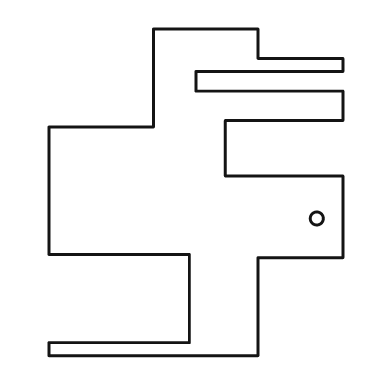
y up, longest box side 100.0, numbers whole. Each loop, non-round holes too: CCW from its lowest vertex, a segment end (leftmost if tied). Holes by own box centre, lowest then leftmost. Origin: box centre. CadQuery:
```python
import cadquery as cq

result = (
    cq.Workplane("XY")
    .moveTo(-45.0, -50.0)
    .lineTo(19.0, -50.0)
    .lineTo(19.0, -20.0)
    .lineTo(45.0, -20.0)
    .lineTo(45.0, 5.0)
    .lineTo(9.0, 5.0)
    .lineTo(9.0, 22.0)
    .lineTo(45.0, 22.0)
    .lineTo(45.0, 31.0)
    .lineTo(0.0, 31.0)
    .lineTo(0.0, 37.0)
    .lineTo(45.0, 37.0)
    .lineTo(45.0, 41.0)
    .lineTo(19.0, 41.0)
    .lineTo(19.0, 50.0)
    .lineTo(-13.0, 50.0)
    .lineTo(-13.0, 20.0)
    .lineTo(-45.0, 20.0)
    .lineTo(-45.0, -19.0)
    .lineTo(-2.0, -19.0)
    .lineTo(-2.0, -46.0)
    .lineTo(-45.0, -46.0)
    .close()
    .moveTo(37.0, -8.0)
    .circle(2.0)
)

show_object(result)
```